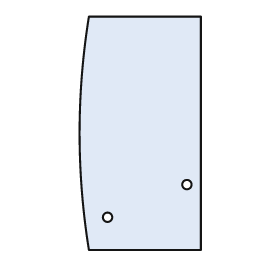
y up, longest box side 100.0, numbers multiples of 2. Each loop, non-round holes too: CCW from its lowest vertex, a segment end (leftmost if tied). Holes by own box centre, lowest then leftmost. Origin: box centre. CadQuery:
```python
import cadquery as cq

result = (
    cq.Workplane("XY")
    .moveTo(-22.0, -50.0)
    .lineTo(26.0, -50.0)
    .lineTo(26.0, 50.0)
    .lineTo(-22.0, 50.0)
    .threePointArc((-26.0, 0.0), (-22.0, -50.0))
    .close()
    .moveTo(-14.0, -36.0)
    .circle(2.0)
    .moveTo(20.0, -22.0)
    .circle(2.0)
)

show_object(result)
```